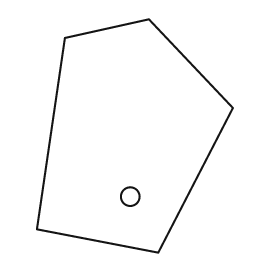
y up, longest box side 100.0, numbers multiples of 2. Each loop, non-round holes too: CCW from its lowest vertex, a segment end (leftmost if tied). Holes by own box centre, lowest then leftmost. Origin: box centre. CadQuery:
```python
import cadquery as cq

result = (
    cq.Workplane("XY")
    .moveTo(10.0, -50.0)
    .lineTo(42.0, 12.0)
    .lineTo(6.0, 50.0)
    .lineTo(-30.0, 42.0)
    .lineTo(-42.0, -40.0)
    .close()
    .moveTo(-2.0, -26.0)
    .circle(4.0)
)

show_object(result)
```